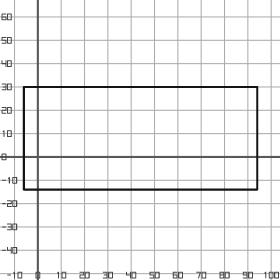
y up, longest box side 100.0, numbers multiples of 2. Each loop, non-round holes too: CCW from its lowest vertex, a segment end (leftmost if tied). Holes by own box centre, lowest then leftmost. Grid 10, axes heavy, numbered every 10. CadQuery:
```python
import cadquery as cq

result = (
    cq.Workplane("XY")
    .moveTo(-6.0, -14.0)
    .lineTo(94.0, -14.0)
    .lineTo(94.0, 30.0)
    .lineTo(-6.0, 30.0)
    .close()
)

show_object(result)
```